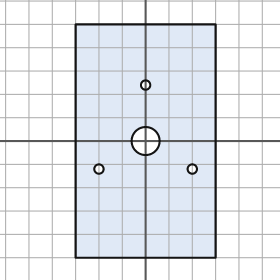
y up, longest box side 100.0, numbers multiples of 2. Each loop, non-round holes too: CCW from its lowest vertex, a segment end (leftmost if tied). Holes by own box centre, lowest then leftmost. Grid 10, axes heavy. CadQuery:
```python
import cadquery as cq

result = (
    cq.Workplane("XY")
    .moveTo(-30.0, -50.0)
    .lineTo(30.0, -50.0)
    .lineTo(30.0, 50.0)
    .lineTo(-30.0, 50.0)
    .close()
    .moveTo(-20.0, -12.0)
    .circle(2.0)
    .moveTo(20.0, -12.0)
    .circle(2.0)
    .moveTo(0.0, 0.0)
    .circle(6.0)
    .moveTo(0.0, 24.0)
    .circle(2.0)
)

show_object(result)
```